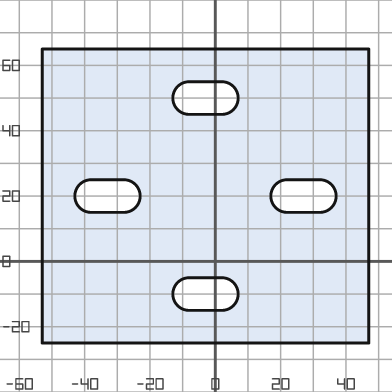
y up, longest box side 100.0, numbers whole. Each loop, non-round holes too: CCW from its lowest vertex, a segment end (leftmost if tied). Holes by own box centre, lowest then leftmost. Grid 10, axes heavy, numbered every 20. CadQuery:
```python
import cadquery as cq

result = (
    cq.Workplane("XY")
    .moveTo(-53.0, -25.0)
    .lineTo(47.0, -25.0)
    .lineTo(47.0, 65.0)
    .lineTo(-53.0, 65.0)
    .close()
    .moveTo(-8.0, -15.0)
    .lineTo(2.0, -15.0)
    .threePointArc((7.0, -10.0), (2.0, -5.0))
    .lineTo(-8.0, -5.0)
    .threePointArc((-13.0, -10.0), (-8.0, -15.0))
    .close()
    .moveTo(-38.0, 15.0)
    .lineTo(-28.0, 15.0)
    .threePointArc((-23.0, 20.0), (-28.0, 25.0))
    .lineTo(-38.0, 25.0)
    .threePointArc((-43.0, 20.0), (-38.0, 15.0))
    .close()
    .moveTo(22.0, 15.0)
    .lineTo(32.0, 15.0)
    .threePointArc((37.0, 20.0), (32.0, 25.0))
    .lineTo(22.0, 25.0)
    .threePointArc((17.0, 20.0), (22.0, 15.0))
    .close()
    .moveTo(-8.0, 45.0)
    .lineTo(2.0, 45.0)
    .threePointArc((7.0, 50.0), (2.0, 55.0))
    .lineTo(-8.0, 55.0)
    .threePointArc((-13.0, 50.0), (-8.0, 45.0))
    .close()
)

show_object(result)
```